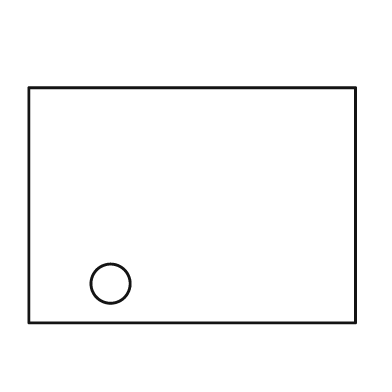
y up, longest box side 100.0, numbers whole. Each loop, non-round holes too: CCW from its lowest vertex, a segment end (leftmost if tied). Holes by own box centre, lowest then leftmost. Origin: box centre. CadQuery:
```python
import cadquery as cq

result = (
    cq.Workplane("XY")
    .moveTo(-50.0, -36.0)
    .lineTo(50.0, -36.0)
    .lineTo(50.0, 36.0)
    .lineTo(-50.0, 36.0)
    .close()
    .moveTo(-25.0, -24.0)
    .circle(6.0)
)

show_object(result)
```